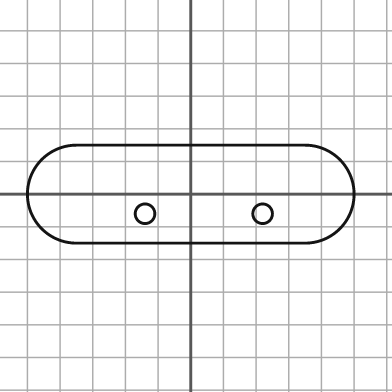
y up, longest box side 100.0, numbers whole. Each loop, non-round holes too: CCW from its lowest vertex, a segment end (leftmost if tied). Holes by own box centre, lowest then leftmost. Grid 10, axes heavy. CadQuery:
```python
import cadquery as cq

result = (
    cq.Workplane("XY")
    .moveTo(-35.0, -15.0)
    .lineTo(35.0, -15.0)
    .threePointArc((50.0, 0.0), (35.0, 15.0))
    .lineTo(-35.0, 15.0)
    .threePointArc((-50.0, 0.0), (-35.0, -15.0))
    .close()
    .moveTo(-14.0, -6.0)
    .circle(3.0)
    .moveTo(22.0, -6.0)
    .circle(3.0)
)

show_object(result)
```